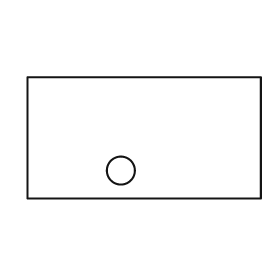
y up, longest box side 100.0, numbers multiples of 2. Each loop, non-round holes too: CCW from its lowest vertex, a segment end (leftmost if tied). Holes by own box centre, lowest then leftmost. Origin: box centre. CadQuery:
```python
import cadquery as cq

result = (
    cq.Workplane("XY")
    .moveTo(-50.0, -26.0)
    .lineTo(50.0, -26.0)
    .lineTo(50.0, 26.0)
    .lineTo(-50.0, 26.0)
    .close()
    .moveTo(-10.0, -14.0)
    .circle(6.0)
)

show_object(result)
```